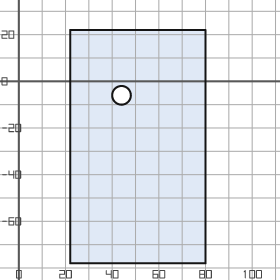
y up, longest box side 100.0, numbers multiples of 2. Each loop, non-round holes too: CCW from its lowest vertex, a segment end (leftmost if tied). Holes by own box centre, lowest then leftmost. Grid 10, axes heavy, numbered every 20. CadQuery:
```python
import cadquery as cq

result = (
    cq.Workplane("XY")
    .moveTo(22.0, -78.0)
    .lineTo(80.0, -78.0)
    .lineTo(80.0, 22.0)
    .lineTo(22.0, 22.0)
    .close()
    .moveTo(44.0, -6.0)
    .circle(4.0)
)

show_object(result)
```